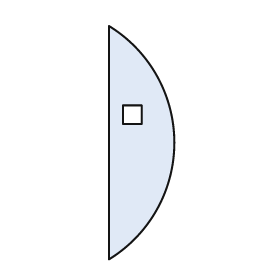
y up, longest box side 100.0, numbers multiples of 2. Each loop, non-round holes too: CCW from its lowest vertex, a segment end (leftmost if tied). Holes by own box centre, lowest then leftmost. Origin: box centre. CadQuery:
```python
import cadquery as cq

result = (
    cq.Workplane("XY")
    .moveTo(-14.0, -50.0)
    .threePointArc((14.0, 0.0), (-14.0, 50.0))
    .close()
    .moveTo(-8.0, 8.0)
    .lineTo(0.0, 8.0)
    .lineTo(0.0, 16.0)
    .lineTo(-8.0, 16.0)
    .close()
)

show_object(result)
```